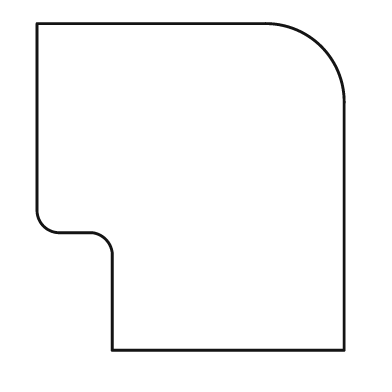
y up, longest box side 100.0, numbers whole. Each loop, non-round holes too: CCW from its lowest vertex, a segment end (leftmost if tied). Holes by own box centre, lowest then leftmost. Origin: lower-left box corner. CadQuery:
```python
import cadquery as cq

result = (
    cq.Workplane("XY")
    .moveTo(23.0, 0.0)
    .lineTo(94.0, 0.0)
    .lineTo(94.0, 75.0)
    .threePointArc((87.0, 93.0), (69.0, 100.0))
    .lineTo(0.0, 100.0)
    .lineTo(0.0, 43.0)
    .threePointArc((2.0, 38.0), (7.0, 36.0))
    .lineTo(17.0, 36.0)
    .threePointArc((21.0, 34.0), (23.0, 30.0))
    .close()
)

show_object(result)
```